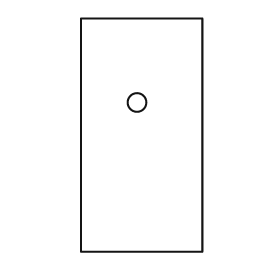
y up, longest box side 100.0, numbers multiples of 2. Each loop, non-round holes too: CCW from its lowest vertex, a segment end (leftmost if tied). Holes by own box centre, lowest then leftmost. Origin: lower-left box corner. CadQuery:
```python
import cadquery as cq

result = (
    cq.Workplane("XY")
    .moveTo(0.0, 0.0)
    .lineTo(52.0, 0.0)
    .lineTo(52.0, 100.0)
    .lineTo(0.0, 100.0)
    .close()
    .moveTo(24.0, 64.0)
    .circle(4.0)
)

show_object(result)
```